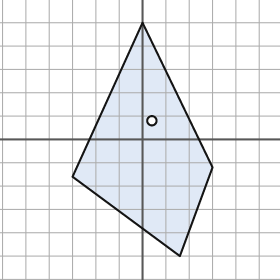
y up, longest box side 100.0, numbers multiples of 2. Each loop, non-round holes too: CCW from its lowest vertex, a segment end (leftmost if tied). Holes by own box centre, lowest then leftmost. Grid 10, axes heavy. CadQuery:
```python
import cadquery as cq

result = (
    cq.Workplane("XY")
    .moveTo(16.0, -50.0)
    .lineTo(30.0, -12.0)
    .lineTo(0.0, 50.0)
    .lineTo(-30.0, -16.0)
    .close()
    .moveTo(4.0, 8.0)
    .circle(2.0)
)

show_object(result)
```